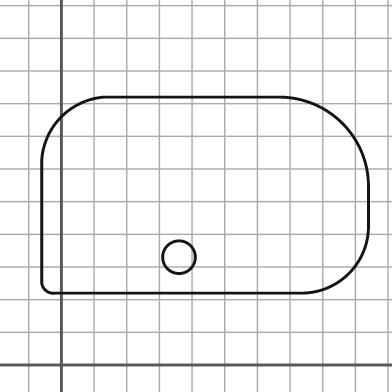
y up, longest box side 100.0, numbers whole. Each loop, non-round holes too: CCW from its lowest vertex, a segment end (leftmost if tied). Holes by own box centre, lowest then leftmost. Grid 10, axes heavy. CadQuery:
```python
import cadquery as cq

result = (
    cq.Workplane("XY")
    .moveTo(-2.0, 22.0)
    .lineTo(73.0, 22.0)
    .threePointArc((88.0, 28.0), (94.0, 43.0))
    .lineTo(94.0, 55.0)
    .threePointArc((86.0, 74.0), (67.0, 82.0))
    .lineTo(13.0, 82.0)
    .threePointArc((0.0, 76.0), (-6.0, 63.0))
    .lineTo(-6.0, 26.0)
    .threePointArc((-5.0, 23.0), (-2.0, 22.0))
    .close()
    .moveTo(36.0, 33.0)
    .circle(5.0)
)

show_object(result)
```